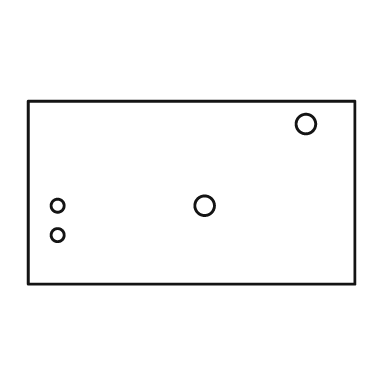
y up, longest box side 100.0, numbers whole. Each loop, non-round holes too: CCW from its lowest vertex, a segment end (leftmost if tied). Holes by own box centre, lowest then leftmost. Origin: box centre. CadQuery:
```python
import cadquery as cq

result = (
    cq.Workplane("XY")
    .moveTo(-50.0, -28.0)
    .lineTo(50.0, -28.0)
    .lineTo(50.0, 28.0)
    .lineTo(-50.0, 28.0)
    .close()
    .moveTo(-41.0, -13.0)
    .circle(2.0)
    .moveTo(-41.0, -4.0)
    .circle(2.0)
    .moveTo(4.0, -4.0)
    .circle(3.0)
    .moveTo(35.0, 21.0)
    .circle(3.0)
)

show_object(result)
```